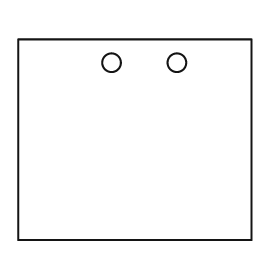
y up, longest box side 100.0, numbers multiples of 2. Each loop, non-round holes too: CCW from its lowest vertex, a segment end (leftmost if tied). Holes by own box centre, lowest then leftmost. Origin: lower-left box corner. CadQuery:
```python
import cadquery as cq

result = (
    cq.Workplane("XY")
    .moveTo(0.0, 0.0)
    .lineTo(100.0, 0.0)
    .lineTo(100.0, 86.0)
    .lineTo(0.0, 86.0)
    .close()
    .moveTo(40.0, 76.0)
    .circle(4.0)
    .moveTo(68.0, 76.0)
    .circle(4.0)
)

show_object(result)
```